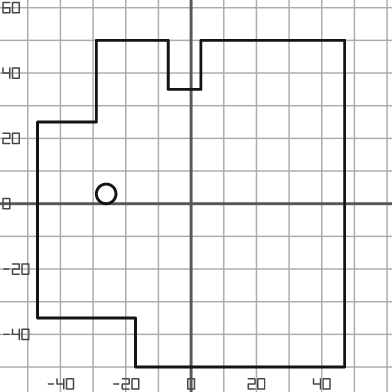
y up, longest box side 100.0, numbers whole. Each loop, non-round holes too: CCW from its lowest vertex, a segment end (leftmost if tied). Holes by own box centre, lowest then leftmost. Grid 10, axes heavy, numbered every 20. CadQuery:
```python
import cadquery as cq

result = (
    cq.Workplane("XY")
    .moveTo(-17.0, -50.0)
    .lineTo(47.0, -50.0)
    .lineTo(47.0, 50.0)
    .lineTo(3.0, 50.0)
    .lineTo(3.0, 35.0)
    .lineTo(-7.0, 35.0)
    .lineTo(-7.0, 50.0)
    .lineTo(-29.0, 50.0)
    .lineTo(-29.0, 25.0)
    .lineTo(-47.0, 25.0)
    .lineTo(-47.0, -35.0)
    .lineTo(-17.0, -35.0)
    .close()
    .moveTo(-26.0, 3.0)
    .circle(3.0)
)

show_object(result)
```